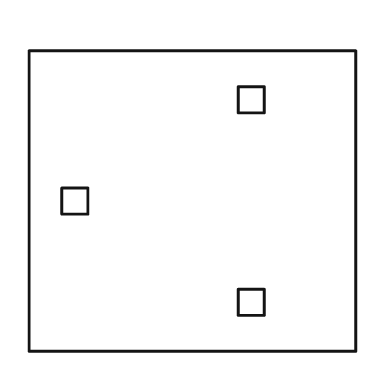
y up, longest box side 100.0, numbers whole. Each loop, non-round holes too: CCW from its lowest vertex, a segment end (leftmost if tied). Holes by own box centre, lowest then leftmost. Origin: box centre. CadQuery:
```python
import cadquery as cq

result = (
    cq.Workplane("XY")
    .moveTo(-50.0, -46.0)
    .lineTo(50.0, -46.0)
    .lineTo(50.0, 46.0)
    .lineTo(-50.0, 46.0)
    .close()
    .moveTo(14.0, -35.0)
    .lineTo(22.0, -35.0)
    .lineTo(22.0, -27.0)
    .lineTo(14.0, -27.0)
    .close()
    .moveTo(-40.0, -4.0)
    .lineTo(-32.0, -4.0)
    .lineTo(-32.0, 4.0)
    .lineTo(-40.0, 4.0)
    .close()
    .moveTo(14.0, 27.0)
    .lineTo(22.0, 27.0)
    .lineTo(22.0, 35.0)
    .lineTo(14.0, 35.0)
    .close()
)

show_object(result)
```